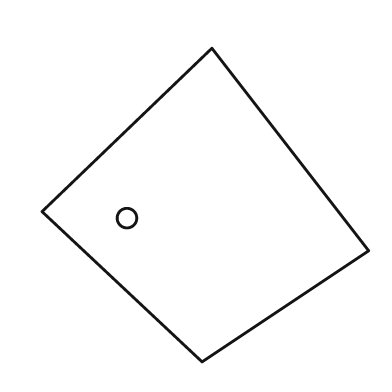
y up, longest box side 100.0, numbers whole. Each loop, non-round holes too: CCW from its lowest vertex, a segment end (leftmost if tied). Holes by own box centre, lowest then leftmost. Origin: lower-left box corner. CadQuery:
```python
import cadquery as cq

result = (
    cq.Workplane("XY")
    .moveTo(49.0, 0.0)
    .lineTo(100.0, 34.0)
    .lineTo(52.0, 96.0)
    .lineTo(0.0, 46.0)
    .close()
    .moveTo(26.0, 44.0)
    .circle(3.0)
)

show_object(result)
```